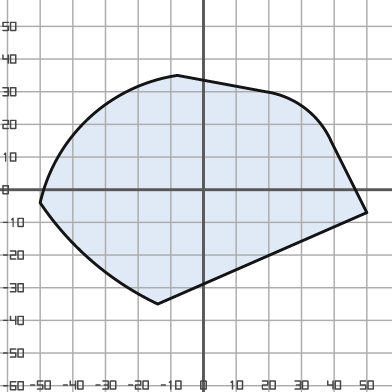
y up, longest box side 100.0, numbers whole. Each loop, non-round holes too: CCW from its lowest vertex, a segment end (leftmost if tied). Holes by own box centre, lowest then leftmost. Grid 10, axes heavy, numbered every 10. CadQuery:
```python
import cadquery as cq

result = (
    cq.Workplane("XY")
    .moveTo(-14.0, -35.0)
    .lineTo(50.0, -7.0)
    .lineTo(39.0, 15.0)
    .threePointArc((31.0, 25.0), (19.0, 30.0))
    .lineTo(-8.0, 35.0)
    .threePointArc((-35.0, 22.0), (-50.0, -4.0))
    .threePointArc((-34.0, -22.0), (-14.0, -35.0))
    .close()
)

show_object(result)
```